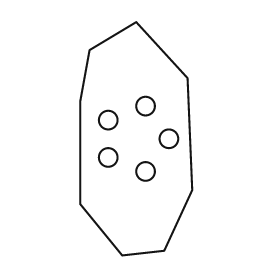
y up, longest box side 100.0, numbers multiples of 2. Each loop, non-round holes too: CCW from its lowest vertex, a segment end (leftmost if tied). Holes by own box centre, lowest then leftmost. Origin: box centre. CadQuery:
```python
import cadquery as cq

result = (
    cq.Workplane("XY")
    .moveTo(-6.0, -50.0)
    .lineTo(12.0, -48.0)
    .lineTo(24.0, -22.0)
    .lineTo(22.0, 26.0)
    .lineTo(0.0, 50.0)
    .lineTo(-20.0, 38.0)
    .lineTo(-24.0, 16.0)
    .lineTo(-24.0, -28.0)
    .close()
    .moveTo(4.0, -14.0)
    .circle(4.0)
    .moveTo(-12.0, -8.0)
    .circle(4.0)
    .moveTo(14.0, 0.0)
    .circle(4.0)
    .moveTo(-12.0, 8.0)
    .circle(4.0)
    .moveTo(4.0, 14.0)
    .circle(4.0)
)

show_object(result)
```